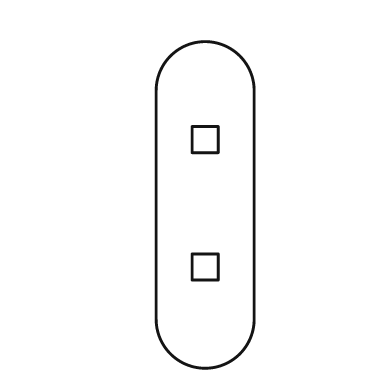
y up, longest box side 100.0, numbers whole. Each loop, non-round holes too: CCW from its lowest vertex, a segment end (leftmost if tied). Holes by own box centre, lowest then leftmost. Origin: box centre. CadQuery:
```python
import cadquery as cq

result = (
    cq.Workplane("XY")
    .moveTo(-15.0, -35.0)
    .threePointArc((0.0, -50.0), (15.0, -35.0))
    .lineTo(15.0, 35.0)
    .threePointArc((0.0, 50.0), (-15.0, 35.0))
    .close()
    .moveTo(-4.0, -23.0)
    .lineTo(4.0, -23.0)
    .lineTo(4.0, -15.0)
    .lineTo(-4.0, -15.0)
    .close()
    .moveTo(-4.0, 16.0)
    .lineTo(4.0, 16.0)
    .lineTo(4.0, 24.0)
    .lineTo(-4.0, 24.0)
    .close()
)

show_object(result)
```